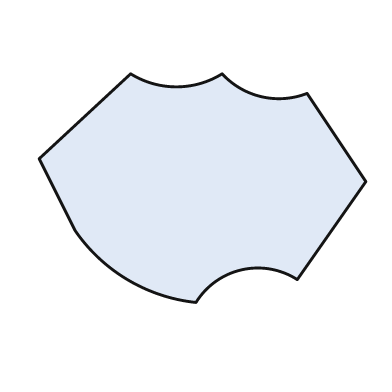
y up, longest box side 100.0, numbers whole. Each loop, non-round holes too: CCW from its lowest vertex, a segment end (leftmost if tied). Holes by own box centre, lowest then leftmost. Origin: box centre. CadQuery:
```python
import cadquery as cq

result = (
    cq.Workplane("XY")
    .moveTo(-2.0, -35.0)
    .threePointArc((12.0, -25.0), (29.0, -28.0))
    .lineTo(50.0, 2.0)
    .lineTo(32.0, 29.0)
    .threePointArc((18.0, 28.0), (6.0, 35.0))
    .threePointArc((-8.0, 31.0), (-22.0, 35.0))
    .lineTo(-50.0, 9.0)
    .lineTo(-39.0, -13.0)
    .threePointArc((-23.0, -28.0), (-2.0, -35.0))
    .close()
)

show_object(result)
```